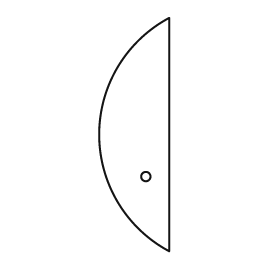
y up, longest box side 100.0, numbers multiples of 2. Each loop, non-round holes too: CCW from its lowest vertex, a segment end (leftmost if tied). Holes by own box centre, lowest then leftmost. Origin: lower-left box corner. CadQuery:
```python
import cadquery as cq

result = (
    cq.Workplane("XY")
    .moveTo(30.0, 0.0)
    .lineTo(30.0, 100.0)
    .threePointArc((0.0, 50.0), (30.0, 0.0))
    .close()
    .moveTo(20.0, 32.0)
    .circle(2.0)
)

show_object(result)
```